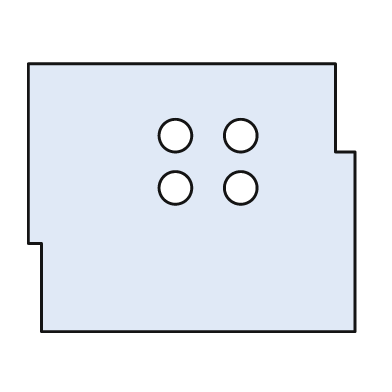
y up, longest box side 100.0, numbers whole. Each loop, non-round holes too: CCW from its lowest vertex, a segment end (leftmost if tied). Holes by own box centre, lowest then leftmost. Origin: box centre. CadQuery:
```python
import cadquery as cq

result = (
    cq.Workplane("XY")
    .moveTo(-46.0, -41.0)
    .lineTo(50.0, -41.0)
    .lineTo(50.0, 14.0)
    .lineTo(44.0, 14.0)
    .lineTo(44.0, 41.0)
    .lineTo(-50.0, 41.0)
    .lineTo(-50.0, -14.0)
    .lineTo(-46.0, -14.0)
    .close()
    .moveTo(-5.0, 3.0)
    .circle(5.0)
    .moveTo(15.0, 3.0)
    .circle(5.0)
    .moveTo(-5.0, 19.0)
    .circle(5.0)
    .moveTo(15.0, 19.0)
    .circle(5.0)
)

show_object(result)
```